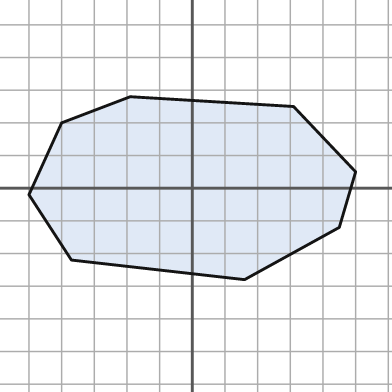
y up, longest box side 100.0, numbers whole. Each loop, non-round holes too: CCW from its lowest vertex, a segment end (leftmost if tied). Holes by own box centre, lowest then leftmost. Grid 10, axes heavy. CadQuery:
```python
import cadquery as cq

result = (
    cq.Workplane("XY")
    .moveTo(16.0, -28.0)
    .lineTo(45.0, -12.0)
    .lineTo(50.0, 5.0)
    .lineTo(31.0, 25.0)
    .lineTo(-19.0, 28.0)
    .lineTo(-40.0, 20.0)
    .lineTo(-50.0, -2.0)
    .lineTo(-37.0, -22.0)
    .close()
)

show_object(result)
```